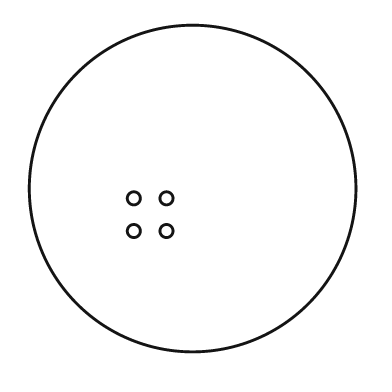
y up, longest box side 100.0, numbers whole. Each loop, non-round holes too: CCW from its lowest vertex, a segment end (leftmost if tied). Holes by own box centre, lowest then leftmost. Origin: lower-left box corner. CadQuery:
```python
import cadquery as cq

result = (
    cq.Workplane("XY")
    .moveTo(50.0, 50.0)
    .circle(50.0)
    .moveTo(32.0, 37.0)
    .circle(2.0)
    .moveTo(42.0, 37.0)
    .circle(2.0)
    .moveTo(32.0, 47.0)
    .circle(2.0)
    .moveTo(42.0, 47.0)
    .circle(2.0)
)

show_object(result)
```